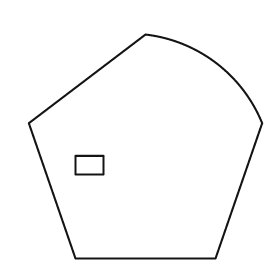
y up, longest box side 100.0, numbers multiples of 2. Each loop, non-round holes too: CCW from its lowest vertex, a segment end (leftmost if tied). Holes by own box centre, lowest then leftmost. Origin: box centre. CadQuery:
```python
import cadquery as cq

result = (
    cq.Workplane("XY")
    .moveTo(-30.0, -48.0)
    .lineTo(30.0, -48.0)
    .lineTo(50.0, 10.0)
    .threePointArc((30.0, 36.0), (0.0, 48.0))
    .lineTo(-50.0, 10.0)
    .close()
    .moveTo(-30.0, -12.0)
    .lineTo(-18.0, -12.0)
    .lineTo(-18.0, -4.0)
    .lineTo(-30.0, -4.0)
    .close()
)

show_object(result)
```